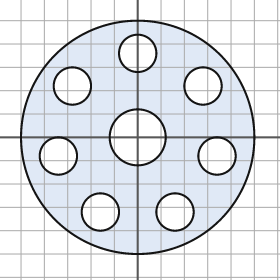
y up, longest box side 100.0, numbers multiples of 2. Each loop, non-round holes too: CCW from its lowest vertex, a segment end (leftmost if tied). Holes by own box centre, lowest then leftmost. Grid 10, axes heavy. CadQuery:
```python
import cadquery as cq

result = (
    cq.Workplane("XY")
    .moveTo(0.0, 0.0)
    .circle(50.0)
    .moveTo(-16.0, -32.0)
    .circle(8.0)
    .moveTo(16.0, -32.0)
    .circle(8.0)
    .moveTo(-34.0, -8.0)
    .circle(8.0)
    .moveTo(34.0, -8.0)
    .circle(8.0)
    .moveTo(0.0, 0.0)
    .circle(12.0)
    .moveTo(-28.0, 22.0)
    .circle(8.0)
    .moveTo(28.0, 22.0)
    .circle(8.0)
    .moveTo(0.0, 36.0)
    .circle(8.0)
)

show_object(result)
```